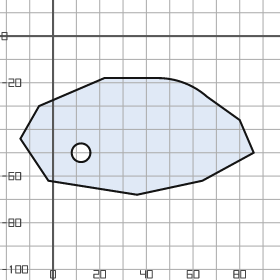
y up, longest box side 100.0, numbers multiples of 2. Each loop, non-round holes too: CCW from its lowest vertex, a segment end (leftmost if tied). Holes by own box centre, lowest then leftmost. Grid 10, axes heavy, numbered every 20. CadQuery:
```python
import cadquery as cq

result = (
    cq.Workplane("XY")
    .moveTo(36.0, -68.0)
    .lineTo(64.0, -62.0)
    .lineTo(86.0, -50.0)
    .lineTo(80.0, -36.0)
    .lineTo(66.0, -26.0)
    .threePointArc((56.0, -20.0), (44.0, -18.0))
    .lineTo(22.0, -18.0)
    .lineTo(-6.0, -30.0)
    .lineTo(-14.0, -44.0)
    .lineTo(-2.0, -62.0)
    .close()
    .moveTo(12.0, -50.0)
    .circle(4.0)
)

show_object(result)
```